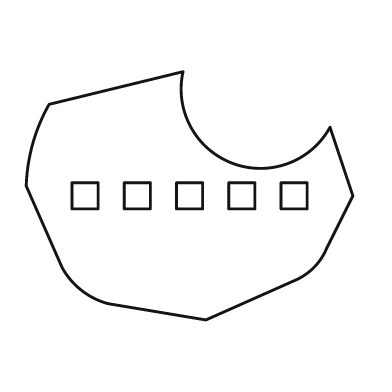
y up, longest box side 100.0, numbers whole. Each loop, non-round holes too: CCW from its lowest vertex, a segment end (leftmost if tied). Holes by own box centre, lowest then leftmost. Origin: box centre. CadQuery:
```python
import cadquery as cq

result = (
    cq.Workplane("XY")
    .moveTo(5.0, -38.0)
    .lineTo(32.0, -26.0)
    .threePointArc((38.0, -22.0), (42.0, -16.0))
    .lineTo(50.0, 0.0)
    .lineTo(43.0, 21.0)
    .threePointArc((13.0, 10.0), (-2.0, 38.0))
    .lineTo(-43.0, 28.0)
    .threePointArc((-48.0, 16.0), (-50.0, 3.0))
    .lineTo(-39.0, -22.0)
    .threePointArc((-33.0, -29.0), (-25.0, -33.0))
    .close()
    .moveTo(-36.0, -4.0)
    .lineTo(-28.0, -4.0)
    .lineTo(-28.0, 4.0)
    .lineTo(-36.0, 4.0)
    .close()
    .moveTo(-20.0, -4.0)
    .lineTo(-12.0, -4.0)
    .lineTo(-12.0, 4.0)
    .lineTo(-20.0, 4.0)
    .close()
    .moveTo(-4.0, -4.0)
    .lineTo(4.0, -4.0)
    .lineTo(4.0, 4.0)
    .lineTo(-4.0, 4.0)
    .close()
    .moveTo(12.0, -4.0)
    .lineTo(20.0, -4.0)
    .lineTo(20.0, 4.0)
    .lineTo(12.0, 4.0)
    .close()
    .moveTo(28.0, -4.0)
    .lineTo(36.0, -4.0)
    .lineTo(36.0, 4.0)
    .lineTo(28.0, 4.0)
    .close()
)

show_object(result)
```